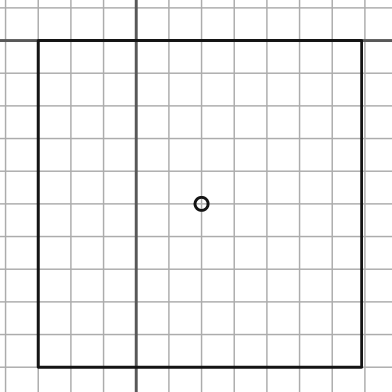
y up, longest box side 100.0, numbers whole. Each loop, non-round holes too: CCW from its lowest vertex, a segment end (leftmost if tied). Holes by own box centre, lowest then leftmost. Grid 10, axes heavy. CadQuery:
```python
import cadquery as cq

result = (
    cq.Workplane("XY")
    .moveTo(-30.0, -100.0)
    .lineTo(69.0, -100.0)
    .lineTo(69.0, 0.0)
    .lineTo(-30.0, 0.0)
    .close()
    .moveTo(20.0, -50.0)
    .circle(2.0)
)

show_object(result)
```